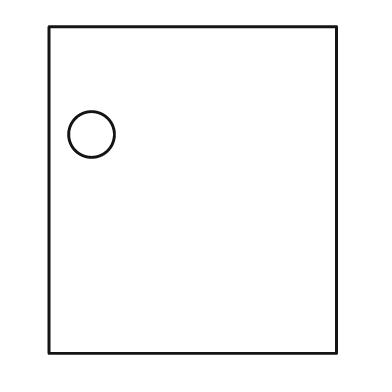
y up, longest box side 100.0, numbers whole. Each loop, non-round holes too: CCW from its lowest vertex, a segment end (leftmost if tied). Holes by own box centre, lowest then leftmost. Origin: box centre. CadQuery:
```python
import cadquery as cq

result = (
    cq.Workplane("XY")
    .moveTo(-44.0, -50.0)
    .lineTo(44.0, -50.0)
    .lineTo(44.0, 50.0)
    .lineTo(-44.0, 50.0)
    .close()
    .moveTo(-31.0, 17.0)
    .circle(7.0)
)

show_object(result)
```